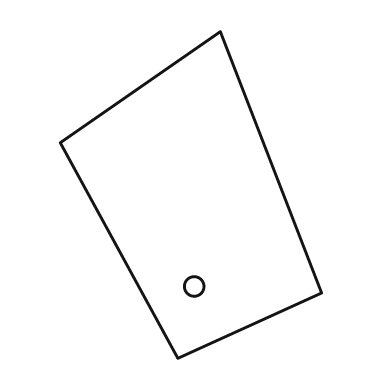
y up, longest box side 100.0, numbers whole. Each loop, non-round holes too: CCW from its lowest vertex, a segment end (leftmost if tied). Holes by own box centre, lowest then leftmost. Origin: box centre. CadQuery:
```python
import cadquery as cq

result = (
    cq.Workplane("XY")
    .moveTo(-4.0, -50.0)
    .lineTo(40.0, -30.0)
    .lineTo(9.0, 50.0)
    .lineTo(-40.0, 16.0)
    .close()
    .moveTo(1.0, -28.0)
    .circle(3.0)
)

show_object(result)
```